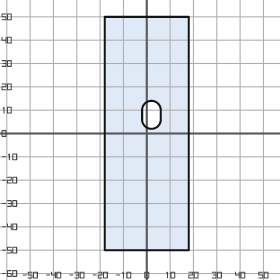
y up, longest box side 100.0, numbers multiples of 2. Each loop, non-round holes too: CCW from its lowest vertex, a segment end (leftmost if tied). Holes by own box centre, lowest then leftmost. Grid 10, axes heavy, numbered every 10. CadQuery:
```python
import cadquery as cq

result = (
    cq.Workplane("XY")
    .moveTo(-18.0, -50.0)
    .lineTo(18.0, -50.0)
    .lineTo(18.0, 50.0)
    .lineTo(-18.0, 50.0)
    .close()
    .moveTo(-2.0, 6.0)
    .threePointArc((2.0, 2.0), (6.0, 6.0))
    .lineTo(6.0, 10.0)
    .threePointArc((2.0, 14.0), (-2.0, 10.0))
    .close()
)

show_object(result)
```